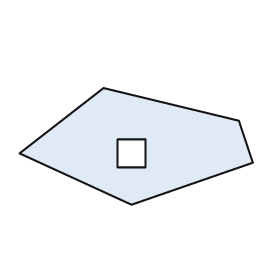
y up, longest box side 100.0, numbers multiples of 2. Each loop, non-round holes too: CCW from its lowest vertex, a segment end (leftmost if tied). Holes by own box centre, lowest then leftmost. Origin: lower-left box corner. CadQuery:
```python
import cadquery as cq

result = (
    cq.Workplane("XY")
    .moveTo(48.0, 0.0)
    .lineTo(100.0, 18.0)
    .lineTo(94.0, 36.0)
    .lineTo(36.0, 50.0)
    .lineTo(0.0, 22.0)
    .close()
    .moveTo(42.0, 16.0)
    .lineTo(54.0, 16.0)
    .lineTo(54.0, 28.0)
    .lineTo(42.0, 28.0)
    .close()
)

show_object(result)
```